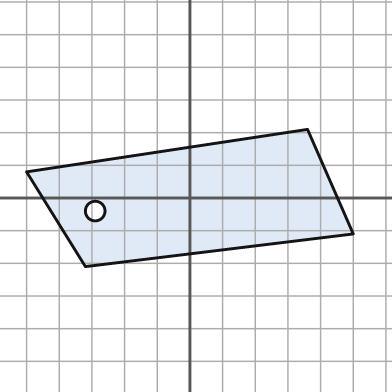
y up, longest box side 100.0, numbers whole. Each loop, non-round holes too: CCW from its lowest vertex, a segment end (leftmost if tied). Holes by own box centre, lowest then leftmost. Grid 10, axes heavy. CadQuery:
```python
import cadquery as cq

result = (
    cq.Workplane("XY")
    .moveTo(-32.0, -21.0)
    .lineTo(50.0, -11.0)
    .lineTo(36.0, 21.0)
    .lineTo(-50.0, 8.0)
    .close()
    .moveTo(-29.0, -4.0)
    .circle(3.0)
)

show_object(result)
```